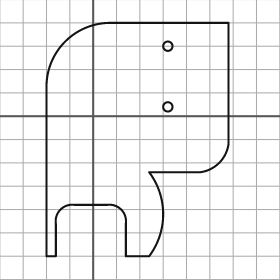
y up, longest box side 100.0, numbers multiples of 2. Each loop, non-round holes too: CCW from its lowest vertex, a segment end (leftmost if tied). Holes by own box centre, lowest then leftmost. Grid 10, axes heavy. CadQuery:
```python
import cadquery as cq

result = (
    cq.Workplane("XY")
    .moveTo(-20.0, -60.0)
    .lineTo(-16.0, -60.0)
    .lineTo(-16.0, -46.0)
    .threePointArc((-14.0, -40.0), (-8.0, -38.0))
    .lineTo(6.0, -38.0)
    .threePointArc((12.0, -40.0), (14.0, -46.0))
    .lineTo(14.0, -60.0)
    .lineTo(24.0, -60.0)
    .threePointArc((30.0, -42.0), (24.0, -24.0))
    .lineTo(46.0, -24.0)
    .threePointArc((54.0, -20.0), (58.0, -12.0))
    .lineTo(58.0, 40.0)
    .lineTo(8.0, 40.0)
    .threePointArc((-12.0, 32.0), (-20.0, 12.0))
    .close()
    .moveTo(32.0, 4.0)
    .circle(2.0)
    .moveTo(32.0, 30.0)
    .circle(2.0)
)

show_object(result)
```